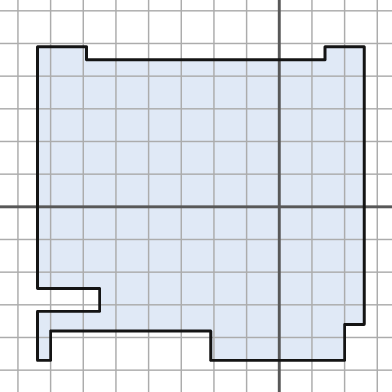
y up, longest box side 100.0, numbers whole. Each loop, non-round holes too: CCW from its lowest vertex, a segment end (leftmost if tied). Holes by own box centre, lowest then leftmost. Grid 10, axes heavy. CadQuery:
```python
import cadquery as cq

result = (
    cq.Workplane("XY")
    .moveTo(-74.0, -47.0)
    .lineTo(-70.0, -47.0)
    .lineTo(-70.0, -38.0)
    .lineTo(-21.0, -38.0)
    .lineTo(-21.0, -47.0)
    .lineTo(20.0, -47.0)
    .lineTo(20.0, -36.0)
    .lineTo(26.0, -36.0)
    .lineTo(26.0, 49.0)
    .lineTo(14.0, 49.0)
    .lineTo(14.0, 45.0)
    .lineTo(-59.0, 45.0)
    .lineTo(-59.0, 49.0)
    .lineTo(-74.0, 49.0)
    .lineTo(-74.0, -25.0)
    .lineTo(-55.0, -25.0)
    .lineTo(-55.0, -32.0)
    .lineTo(-74.0, -32.0)
    .close()
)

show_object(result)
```